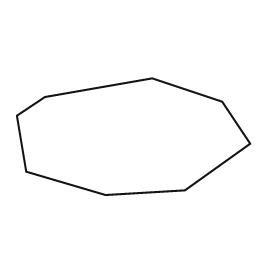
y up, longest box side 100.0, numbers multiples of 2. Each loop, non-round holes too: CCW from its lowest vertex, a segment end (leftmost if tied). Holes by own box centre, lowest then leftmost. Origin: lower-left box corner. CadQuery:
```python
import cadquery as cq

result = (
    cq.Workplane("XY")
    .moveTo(38.0, 0.0)
    .lineTo(72.0, 2.0)
    .lineTo(100.0, 22.0)
    .lineTo(88.0, 40.0)
    .lineTo(58.0, 50.0)
    .lineTo(12.0, 42.0)
    .lineTo(0.0, 34.0)
    .lineTo(4.0, 10.0)
    .close()
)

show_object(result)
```